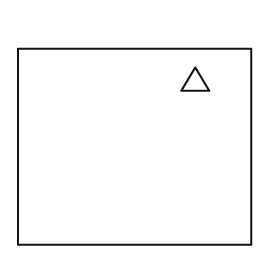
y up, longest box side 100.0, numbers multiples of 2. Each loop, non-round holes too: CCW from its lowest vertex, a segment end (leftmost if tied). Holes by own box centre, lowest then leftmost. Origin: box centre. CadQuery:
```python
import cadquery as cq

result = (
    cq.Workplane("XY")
    .moveTo(-50.0, -42.0)
    .lineTo(50.0, -42.0)
    .lineTo(50.0, 42.0)
    .lineTo(-50.0, 42.0)
    .close()
    .moveTo(20.0, 24.0)
    .lineTo(32.0, 24.0)
    .lineTo(26.0, 34.0)
    .close()
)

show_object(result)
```